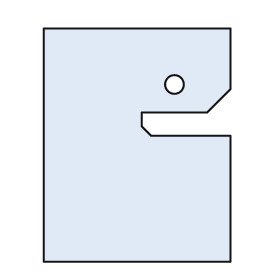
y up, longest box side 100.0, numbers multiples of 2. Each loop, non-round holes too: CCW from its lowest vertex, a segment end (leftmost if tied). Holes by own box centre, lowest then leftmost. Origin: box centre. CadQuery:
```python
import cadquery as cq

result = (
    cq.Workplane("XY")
    .moveTo(-40.0, -50.0)
    .lineTo(40.0, -50.0)
    .lineTo(40.0, 4.0)
    .lineTo(6.0, 4.0)
    .lineTo(2.0, 8.0)
    .lineTo(2.0, 14.0)
    .lineTo(30.0, 14.0)
    .lineTo(40.0, 24.0)
    .lineTo(40.0, 50.0)
    .lineTo(-40.0, 50.0)
    .close()
    .moveTo(16.0, 26.0)
    .circle(4.0)
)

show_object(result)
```